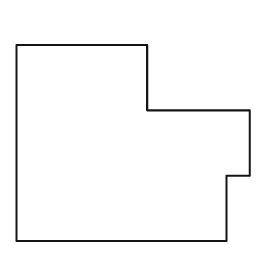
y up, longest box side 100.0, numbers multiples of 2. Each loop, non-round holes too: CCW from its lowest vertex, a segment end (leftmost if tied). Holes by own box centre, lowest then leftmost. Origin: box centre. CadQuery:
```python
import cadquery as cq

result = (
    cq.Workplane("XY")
    .moveTo(-50.0, -42.0)
    .lineTo(40.0, -42.0)
    .lineTo(40.0, -14.0)
    .lineTo(50.0, -14.0)
    .lineTo(50.0, 14.0)
    .lineTo(6.0, 14.0)
    .lineTo(6.0, 42.0)
    .lineTo(-50.0, 42.0)
    .close()
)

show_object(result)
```